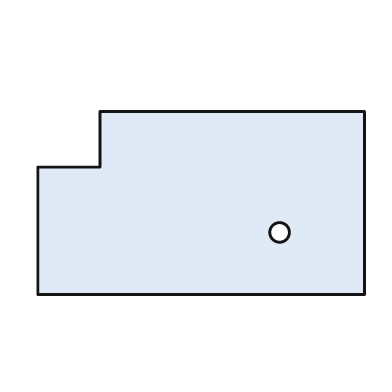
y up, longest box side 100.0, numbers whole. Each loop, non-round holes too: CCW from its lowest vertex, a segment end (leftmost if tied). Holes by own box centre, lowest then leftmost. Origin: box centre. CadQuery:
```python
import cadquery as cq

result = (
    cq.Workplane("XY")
    .moveTo(-50.0, -28.0)
    .lineTo(50.0, -28.0)
    .lineTo(50.0, 28.0)
    .lineTo(-31.0, 28.0)
    .lineTo(-31.0, 11.0)
    .lineTo(-50.0, 11.0)
    .close()
    .moveTo(24.0, -9.0)
    .circle(3.0)
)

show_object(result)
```